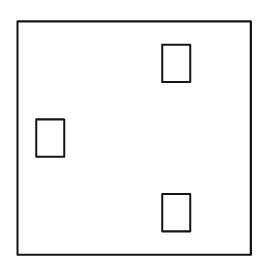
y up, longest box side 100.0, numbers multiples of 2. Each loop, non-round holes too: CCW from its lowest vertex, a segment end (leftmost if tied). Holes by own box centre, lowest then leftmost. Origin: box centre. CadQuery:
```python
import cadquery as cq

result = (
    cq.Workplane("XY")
    .moveTo(-50.0, -50.0)
    .lineTo(50.0, -50.0)
    .lineTo(50.0, 50.0)
    .lineTo(-50.0, 50.0)
    .close()
    .moveTo(12.0, -40.0)
    .lineTo(24.0, -40.0)
    .lineTo(24.0, -24.0)
    .lineTo(12.0, -24.0)
    .close()
    .moveTo(-42.0, -8.0)
    .lineTo(-30.0, -8.0)
    .lineTo(-30.0, 8.0)
    .lineTo(-42.0, 8.0)
    .close()
    .moveTo(12.0, 24.0)
    .lineTo(24.0, 24.0)
    .lineTo(24.0, 40.0)
    .lineTo(12.0, 40.0)
    .close()
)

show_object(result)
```